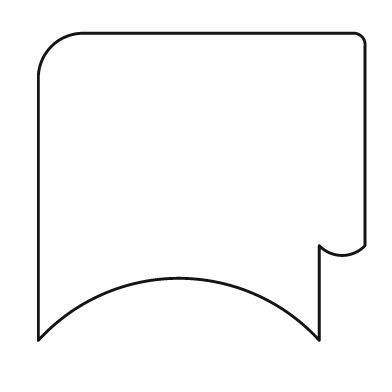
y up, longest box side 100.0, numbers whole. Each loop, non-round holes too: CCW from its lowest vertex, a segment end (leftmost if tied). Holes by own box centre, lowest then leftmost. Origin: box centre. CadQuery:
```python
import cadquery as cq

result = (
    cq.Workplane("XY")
    .moveTo(-50.0, -47.0)
    .threePointArc((-7.0, -28.0), (36.0, -47.0))
    .lineTo(36.0, -18.0)
    .threePointArc((43.0, -21.0), (50.0, -18.0))
    .lineTo(50.0, 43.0)
    .threePointArc((49.0, 46.0), (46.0, 47.0))
    .lineTo(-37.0, 47.0)
    .threePointArc((-46.0, 43.0), (-50.0, 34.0))
    .close()
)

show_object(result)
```